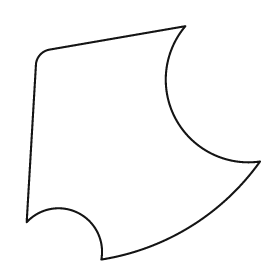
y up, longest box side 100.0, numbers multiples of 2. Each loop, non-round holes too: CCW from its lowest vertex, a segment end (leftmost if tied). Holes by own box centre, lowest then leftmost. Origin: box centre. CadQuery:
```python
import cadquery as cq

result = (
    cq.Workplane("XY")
    .moveTo(-18.0, -50.0)
    .threePointArc((20.0, -36.0), (50.0, -8.0))
    .threePointArc((14.0, 10.0), (18.0, 50.0))
    .lineTo(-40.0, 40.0)
    .threePointArc((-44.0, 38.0), (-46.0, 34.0))
    .lineTo(-50.0, -34.0)
    .threePointArc((-28.0, -30.0), (-18.0, -50.0))
    .close()
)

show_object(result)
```